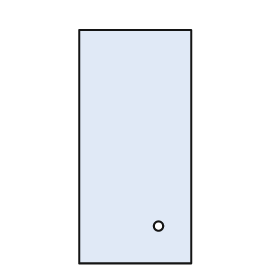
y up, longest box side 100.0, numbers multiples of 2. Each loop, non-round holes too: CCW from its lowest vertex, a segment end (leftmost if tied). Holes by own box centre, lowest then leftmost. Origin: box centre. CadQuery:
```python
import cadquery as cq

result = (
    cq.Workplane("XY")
    .moveTo(-24.0, -50.0)
    .lineTo(24.0, -50.0)
    .lineTo(24.0, 50.0)
    .lineTo(-24.0, 50.0)
    .close()
    .moveTo(10.0, -34.0)
    .circle(2.0)
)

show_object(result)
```